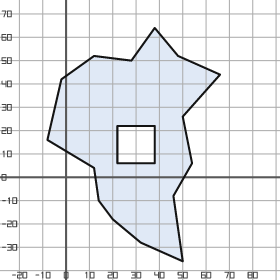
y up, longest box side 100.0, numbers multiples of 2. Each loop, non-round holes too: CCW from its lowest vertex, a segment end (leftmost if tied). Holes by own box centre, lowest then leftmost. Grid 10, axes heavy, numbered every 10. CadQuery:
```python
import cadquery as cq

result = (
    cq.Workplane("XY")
    .moveTo(50.0, -36.0)
    .lineTo(46.0, -8.0)
    .lineTo(54.0, 6.0)
    .lineTo(50.0, 26.0)
    .lineTo(66.0, 44.0)
    .lineTo(48.0, 52.0)
    .lineTo(38.0, 64.0)
    .lineTo(28.0, 50.0)
    .lineTo(12.0, 52.0)
    .lineTo(-2.0, 42.0)
    .lineTo(-8.0, 16.0)
    .lineTo(12.0, 4.0)
    .lineTo(14.0, -10.0)
    .lineTo(20.0, -18.0)
    .lineTo(32.0, -28.0)
    .close()
    .moveTo(22.0, 6.0)
    .lineTo(38.0, 6.0)
    .lineTo(38.0, 22.0)
    .lineTo(22.0, 22.0)
    .close()
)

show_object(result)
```